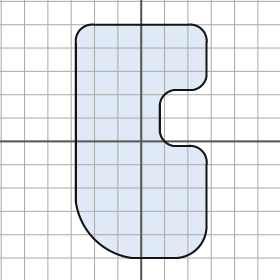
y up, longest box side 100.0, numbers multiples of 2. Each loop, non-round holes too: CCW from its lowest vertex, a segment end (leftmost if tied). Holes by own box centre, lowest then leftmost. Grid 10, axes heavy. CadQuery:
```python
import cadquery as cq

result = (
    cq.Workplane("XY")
    .moveTo(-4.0, -50.0)
    .lineTo(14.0, -50.0)
    .threePointArc((24.0, -46.0), (28.0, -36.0))
    .lineTo(28.0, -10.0)
    .threePointArc((26.0, -4.0), (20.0, -2.0))
    .lineTo(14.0, -2.0)
    .threePointArc((10.0, 0.0), (8.0, 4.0))
    .lineTo(8.0, 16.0)
    .threePointArc((10.0, 20.0), (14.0, 22.0))
    .lineTo(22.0, 22.0)
    .threePointArc((26.0, 24.0), (28.0, 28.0))
    .lineTo(28.0, 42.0)
    .threePointArc((26.0, 48.0), (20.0, 50.0))
    .lineTo(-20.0, 50.0)
    .threePointArc((-26.0, 48.0), (-28.0, 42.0))
    .lineTo(-28.0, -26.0)
    .threePointArc((-20.0, -42.0), (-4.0, -50.0))
    .close()
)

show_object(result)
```